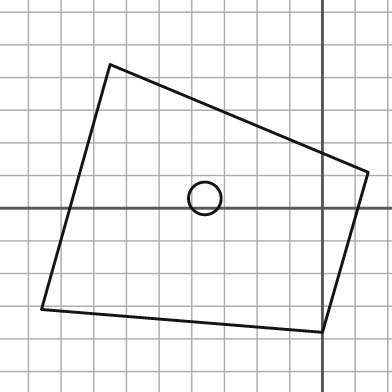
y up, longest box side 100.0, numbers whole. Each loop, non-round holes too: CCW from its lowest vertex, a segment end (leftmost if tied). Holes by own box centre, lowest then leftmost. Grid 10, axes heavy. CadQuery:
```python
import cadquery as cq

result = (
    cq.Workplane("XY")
    .moveTo(0.0, -38.0)
    .lineTo(14.0, 11.0)
    .lineTo(-65.0, 44.0)
    .lineTo(-86.0, -31.0)
    .close()
    .moveTo(-36.0, 3.0)
    .circle(5.0)
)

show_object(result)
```